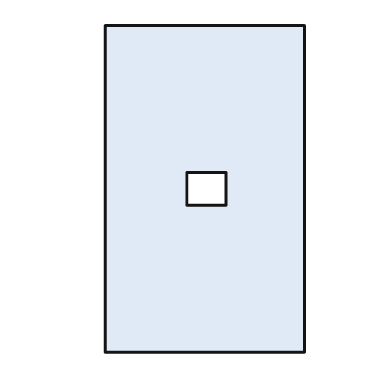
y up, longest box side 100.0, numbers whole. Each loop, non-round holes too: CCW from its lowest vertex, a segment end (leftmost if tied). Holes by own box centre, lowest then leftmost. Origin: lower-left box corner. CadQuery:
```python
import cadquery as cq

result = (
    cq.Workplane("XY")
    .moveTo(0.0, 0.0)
    .lineTo(61.0, 0.0)
    .lineTo(61.0, 100.0)
    .lineTo(0.0, 100.0)
    .close()
    .moveTo(25.0, 45.0)
    .lineTo(37.0, 45.0)
    .lineTo(37.0, 55.0)
    .lineTo(25.0, 55.0)
    .close()
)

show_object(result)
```